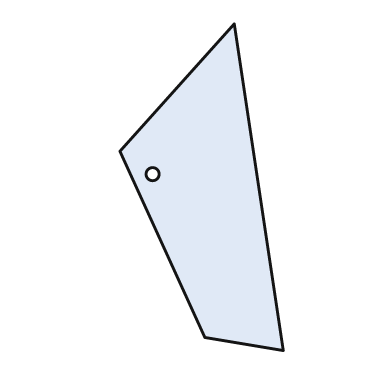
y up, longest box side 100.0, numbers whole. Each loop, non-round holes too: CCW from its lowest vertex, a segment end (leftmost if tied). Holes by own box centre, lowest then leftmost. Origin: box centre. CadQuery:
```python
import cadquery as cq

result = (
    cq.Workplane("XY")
    .moveTo(25.0, -50.0)
    .lineTo(10.0, 50.0)
    .lineTo(-25.0, 11.0)
    .lineTo(1.0, -46.0)
    .close()
    .moveTo(-15.0, 4.0)
    .circle(2.0)
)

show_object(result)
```